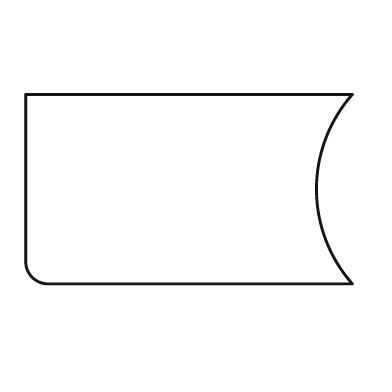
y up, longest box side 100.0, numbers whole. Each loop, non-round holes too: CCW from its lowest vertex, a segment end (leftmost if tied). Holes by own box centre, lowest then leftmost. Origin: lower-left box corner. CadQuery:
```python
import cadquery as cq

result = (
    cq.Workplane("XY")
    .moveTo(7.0, 0.0)
    .lineTo(100.0, 0.0)
    .threePointArc((89.0, 29.0), (100.0, 58.0))
    .lineTo(0.0, 58.0)
    .lineTo(0.0, 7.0)
    .threePointArc((2.0, 2.0), (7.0, 0.0))
    .close()
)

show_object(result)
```